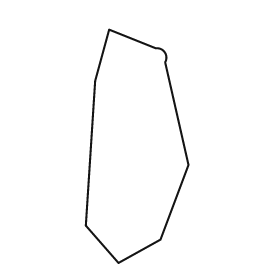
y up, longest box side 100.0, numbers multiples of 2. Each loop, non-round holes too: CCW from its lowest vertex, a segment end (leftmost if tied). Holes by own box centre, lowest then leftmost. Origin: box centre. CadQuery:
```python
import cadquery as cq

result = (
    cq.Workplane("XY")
    .moveTo(-8.0, -50.0)
    .lineTo(10.0, -40.0)
    .lineTo(22.0, -8.0)
    .lineTo(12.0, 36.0)
    .threePointArc((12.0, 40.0), (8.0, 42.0))
    .lineTo(-12.0, 50.0)
    .lineTo(-18.0, 28.0)
    .lineTo(-22.0, -34.0)
    .close()
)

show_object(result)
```